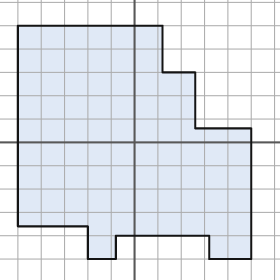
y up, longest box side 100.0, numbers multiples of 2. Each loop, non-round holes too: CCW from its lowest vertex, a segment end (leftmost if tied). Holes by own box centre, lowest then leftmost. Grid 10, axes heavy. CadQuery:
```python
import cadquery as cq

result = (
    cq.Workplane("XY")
    .moveTo(-20.0, -50.0)
    .lineTo(-8.0, -50.0)
    .lineTo(-8.0, -40.0)
    .lineTo(32.0, -40.0)
    .lineTo(32.0, -50.0)
    .lineTo(50.0, -50.0)
    .lineTo(50.0, 6.0)
    .lineTo(26.0, 6.0)
    .lineTo(26.0, 30.0)
    .lineTo(12.0, 30.0)
    .lineTo(12.0, 50.0)
    .lineTo(-50.0, 50.0)
    .lineTo(-50.0, -36.0)
    .lineTo(-20.0, -36.0)
    .close()
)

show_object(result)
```